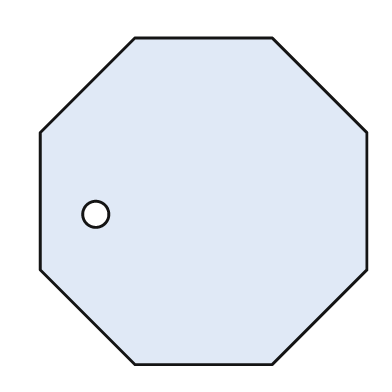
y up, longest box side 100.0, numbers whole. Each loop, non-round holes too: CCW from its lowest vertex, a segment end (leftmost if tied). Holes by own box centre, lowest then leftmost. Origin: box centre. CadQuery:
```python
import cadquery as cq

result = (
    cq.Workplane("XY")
    .moveTo(-21.0, -50.0)
    .lineTo(21.0, -50.0)
    .lineTo(50.0, -21.0)
    .lineTo(50.0, 21.0)
    .lineTo(21.0, 50.0)
    .lineTo(-21.0, 50.0)
    .lineTo(-50.0, 21.0)
    .lineTo(-50.0, -21.0)
    .close()
    .moveTo(-33.0, -4.0)
    .circle(4.0)
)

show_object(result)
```